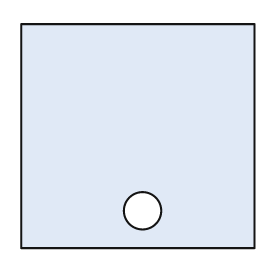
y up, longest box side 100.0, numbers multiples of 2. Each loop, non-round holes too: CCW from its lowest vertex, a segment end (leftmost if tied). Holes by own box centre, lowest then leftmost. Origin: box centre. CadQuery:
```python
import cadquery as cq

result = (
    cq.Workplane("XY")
    .moveTo(-50.0, -48.0)
    .lineTo(50.0, -48.0)
    .lineTo(50.0, 48.0)
    .lineTo(-50.0, 48.0)
    .close()
    .moveTo(2.0, -32.0)
    .circle(8.0)
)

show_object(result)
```